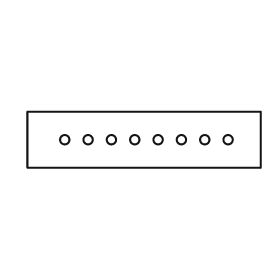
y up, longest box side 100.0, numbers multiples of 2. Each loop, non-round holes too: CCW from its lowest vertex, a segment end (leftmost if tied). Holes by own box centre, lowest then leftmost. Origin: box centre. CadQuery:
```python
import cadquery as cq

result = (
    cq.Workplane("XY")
    .moveTo(-50.0, -12.0)
    .lineTo(50.0, -12.0)
    .lineTo(50.0, 12.0)
    .lineTo(-50.0, 12.0)
    .close()
    .moveTo(-34.0, 0.0)
    .circle(2.0)
    .moveTo(-24.0, 0.0)
    .circle(2.0)
    .moveTo(-14.0, 0.0)
    .circle(2.0)
    .moveTo(-4.0, 0.0)
    .circle(2.0)
    .moveTo(6.0, 0.0)
    .circle(2.0)
    .moveTo(16.0, 0.0)
    .circle(2.0)
    .moveTo(26.0, 0.0)
    .circle(2.0)
    .moveTo(36.0, 0.0)
    .circle(2.0)
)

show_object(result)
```